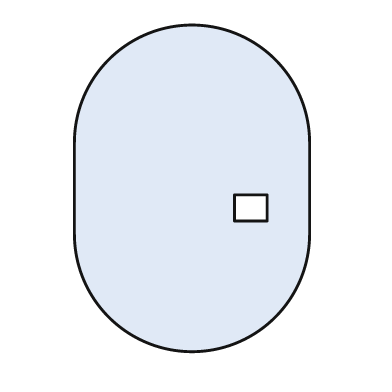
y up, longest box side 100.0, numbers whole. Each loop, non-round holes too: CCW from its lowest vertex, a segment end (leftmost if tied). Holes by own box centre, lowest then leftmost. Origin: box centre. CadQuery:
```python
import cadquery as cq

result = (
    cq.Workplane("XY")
    .moveTo(-36.0, -14.0)
    .threePointArc((0.0, -50.0), (36.0, -14.0))
    .lineTo(36.0, 14.0)
    .threePointArc((0.0, 50.0), (-36.0, 14.0))
    .close()
    .moveTo(13.0, -10.0)
    .lineTo(23.0, -10.0)
    .lineTo(23.0, -2.0)
    .lineTo(13.0, -2.0)
    .close()
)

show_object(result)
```